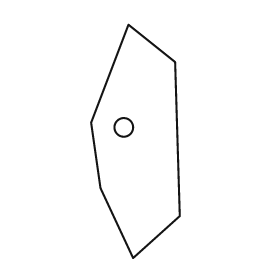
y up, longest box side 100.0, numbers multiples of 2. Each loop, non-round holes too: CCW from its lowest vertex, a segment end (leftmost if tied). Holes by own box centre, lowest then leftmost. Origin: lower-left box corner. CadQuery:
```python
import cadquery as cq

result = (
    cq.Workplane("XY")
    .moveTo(18.0, 0.0)
    .lineTo(38.0, 18.0)
    .lineTo(36.0, 84.0)
    .lineTo(16.0, 100.0)
    .lineTo(0.0, 58.0)
    .lineTo(4.0, 30.0)
    .close()
    .moveTo(14.0, 56.0)
    .circle(4.0)
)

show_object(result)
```